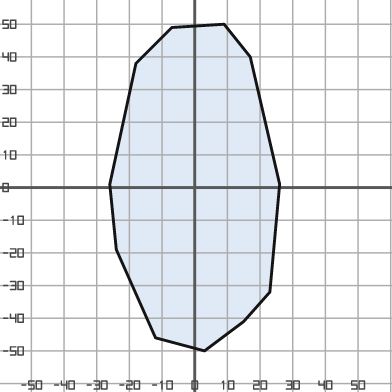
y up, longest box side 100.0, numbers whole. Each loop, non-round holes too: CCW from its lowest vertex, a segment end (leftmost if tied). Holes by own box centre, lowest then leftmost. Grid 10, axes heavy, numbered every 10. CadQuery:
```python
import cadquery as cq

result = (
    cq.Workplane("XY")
    .moveTo(3.0, -50.0)
    .lineTo(15.0, -41.0)
    .lineTo(23.0, -32.0)
    .lineTo(26.0, 1.0)
    .lineTo(17.0, 40.0)
    .lineTo(9.0, 50.0)
    .lineTo(-7.0, 49.0)
    .lineTo(-18.0, 38.0)
    .lineTo(-26.0, 1.0)
    .lineTo(-24.0, -19.0)
    .lineTo(-12.0, -46.0)
    .close()
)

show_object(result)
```